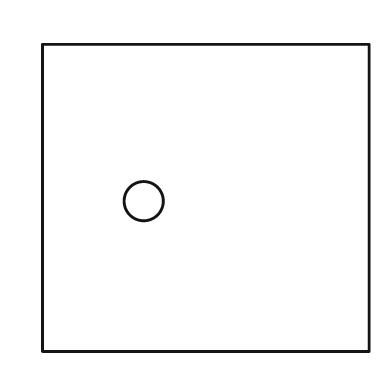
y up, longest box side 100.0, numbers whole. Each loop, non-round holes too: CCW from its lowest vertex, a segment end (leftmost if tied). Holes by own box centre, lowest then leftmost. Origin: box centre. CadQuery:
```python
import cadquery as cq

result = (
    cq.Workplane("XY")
    .moveTo(-50.0, -47.0)
    .lineTo(50.0, -47.0)
    .lineTo(50.0, 47.0)
    .lineTo(-50.0, 47.0)
    .close()
    .moveTo(-19.0, -1.0)
    .circle(6.0)
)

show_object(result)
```